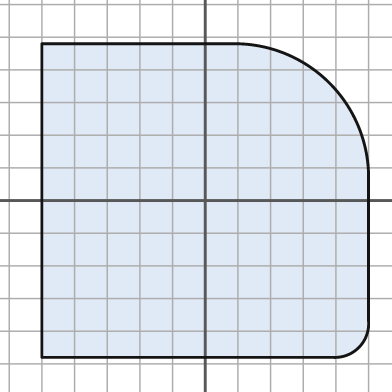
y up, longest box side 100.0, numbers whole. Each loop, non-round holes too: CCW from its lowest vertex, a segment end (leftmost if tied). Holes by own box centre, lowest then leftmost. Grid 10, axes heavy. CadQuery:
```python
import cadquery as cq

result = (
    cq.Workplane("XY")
    .moveTo(-50.0, -48.0)
    .lineTo(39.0, -48.0)
    .threePointArc((47.0, -45.0), (50.0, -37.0))
    .lineTo(50.0, 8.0)
    .threePointArc((38.0, 36.0), (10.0, 48.0))
    .lineTo(-50.0, 48.0)
    .close()
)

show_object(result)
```